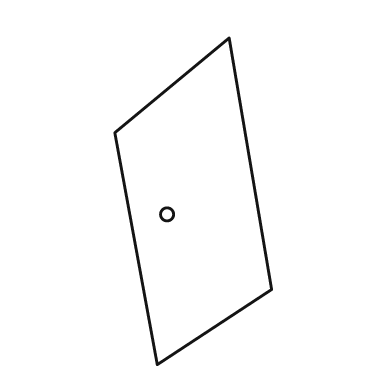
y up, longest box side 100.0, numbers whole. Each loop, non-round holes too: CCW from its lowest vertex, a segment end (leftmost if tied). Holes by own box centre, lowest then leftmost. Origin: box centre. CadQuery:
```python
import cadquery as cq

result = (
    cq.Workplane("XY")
    .moveTo(-11.0, -50.0)
    .lineTo(24.0, -27.0)
    .lineTo(11.0, 50.0)
    .lineTo(-24.0, 21.0)
    .close()
    .moveTo(-8.0, -4.0)
    .circle(2.0)
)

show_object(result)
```